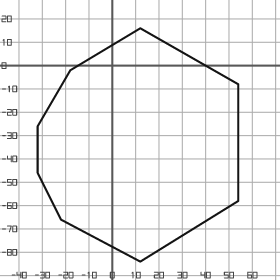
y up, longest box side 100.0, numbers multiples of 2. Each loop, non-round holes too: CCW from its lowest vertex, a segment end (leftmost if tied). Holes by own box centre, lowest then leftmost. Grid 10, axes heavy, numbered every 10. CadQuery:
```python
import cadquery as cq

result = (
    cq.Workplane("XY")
    .moveTo(12.0, -84.0)
    .lineTo(54.0, -58.0)
    .lineTo(54.0, -8.0)
    .lineTo(12.0, 16.0)
    .lineTo(-18.0, -2.0)
    .lineTo(-32.0, -26.0)
    .lineTo(-32.0, -46.0)
    .lineTo(-22.0, -66.0)
    .close()
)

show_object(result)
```